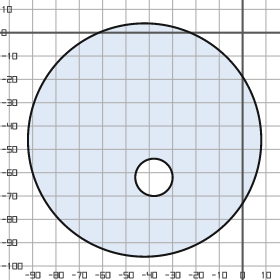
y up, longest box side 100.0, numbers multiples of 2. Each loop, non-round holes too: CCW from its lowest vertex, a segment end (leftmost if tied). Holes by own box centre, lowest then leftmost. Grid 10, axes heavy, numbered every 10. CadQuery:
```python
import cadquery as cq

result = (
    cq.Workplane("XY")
    .moveTo(-42.0, -46.0)
    .circle(50.0)
    .moveTo(-38.0, -62.0)
    .circle(8.0)
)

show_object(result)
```